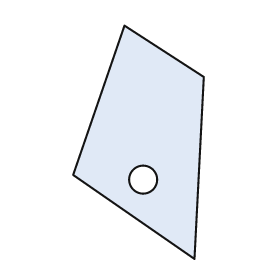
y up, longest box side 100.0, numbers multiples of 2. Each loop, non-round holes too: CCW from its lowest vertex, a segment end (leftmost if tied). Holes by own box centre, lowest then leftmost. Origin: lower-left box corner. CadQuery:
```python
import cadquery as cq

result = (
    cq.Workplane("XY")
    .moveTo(52.0, 0.0)
    .lineTo(56.0, 78.0)
    .lineTo(22.0, 100.0)
    .lineTo(0.0, 36.0)
    .close()
    .moveTo(30.0, 34.0)
    .circle(6.0)
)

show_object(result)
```